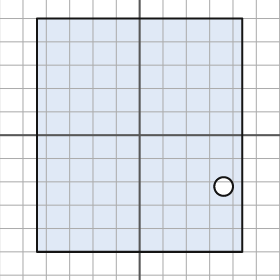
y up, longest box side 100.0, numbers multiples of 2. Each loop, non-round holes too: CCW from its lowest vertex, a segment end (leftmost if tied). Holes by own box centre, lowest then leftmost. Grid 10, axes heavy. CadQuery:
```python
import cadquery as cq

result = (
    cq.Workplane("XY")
    .moveTo(-44.0, -50.0)
    .lineTo(44.0, -50.0)
    .lineTo(44.0, 50.0)
    .lineTo(-44.0, 50.0)
    .close()
    .moveTo(36.0, -22.0)
    .circle(4.0)
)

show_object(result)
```